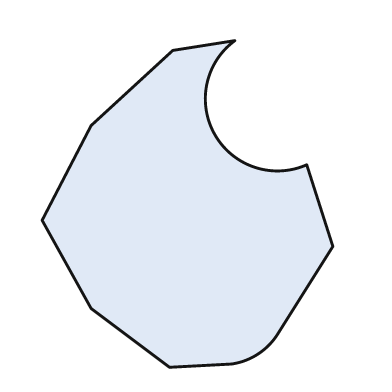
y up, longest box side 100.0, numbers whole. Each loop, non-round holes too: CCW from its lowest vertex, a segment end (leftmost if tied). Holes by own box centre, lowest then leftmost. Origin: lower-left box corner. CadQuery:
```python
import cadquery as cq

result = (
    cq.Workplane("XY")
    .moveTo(39.0, 0.0)
    .lineTo(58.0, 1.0)
    .threePointArc((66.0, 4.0), (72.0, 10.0))
    .lineTo(89.0, 37.0)
    .lineTo(81.0, 62.0)
    .threePointArc((53.0, 71.0), (59.0, 100.0))
    .lineTo(40.0, 97.0)
    .lineTo(15.0, 74.0)
    .lineTo(0.0, 45.0)
    .lineTo(15.0, 18.0)
    .close()
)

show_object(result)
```